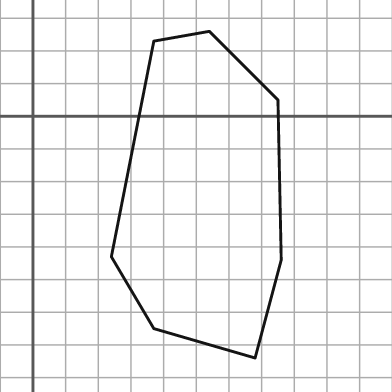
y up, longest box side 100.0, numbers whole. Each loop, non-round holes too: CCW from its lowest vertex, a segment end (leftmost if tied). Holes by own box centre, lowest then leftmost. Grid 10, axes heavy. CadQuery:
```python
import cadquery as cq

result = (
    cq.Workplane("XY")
    .moveTo(68.0, -74.0)
    .lineTo(76.0, -44.0)
    .lineTo(75.0, 5.0)
    .lineTo(54.0, 26.0)
    .lineTo(37.0, 23.0)
    .lineTo(24.0, -43.0)
    .lineTo(37.0, -65.0)
    .close()
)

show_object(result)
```